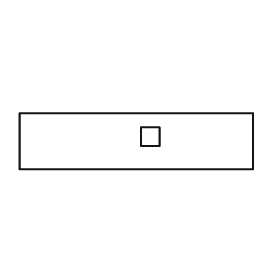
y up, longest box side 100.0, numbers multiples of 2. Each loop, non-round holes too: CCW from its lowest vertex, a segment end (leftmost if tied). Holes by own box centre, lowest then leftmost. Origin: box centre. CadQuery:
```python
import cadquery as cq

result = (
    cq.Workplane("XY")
    .moveTo(-50.0, -12.0)
    .lineTo(50.0, -12.0)
    .lineTo(50.0, 12.0)
    .lineTo(-50.0, 12.0)
    .close()
    .moveTo(2.0, -2.0)
    .lineTo(10.0, -2.0)
    .lineTo(10.0, 6.0)
    .lineTo(2.0, 6.0)
    .close()
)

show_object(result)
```